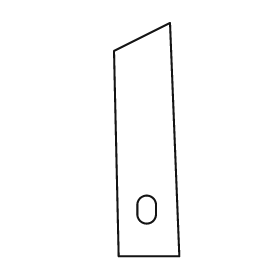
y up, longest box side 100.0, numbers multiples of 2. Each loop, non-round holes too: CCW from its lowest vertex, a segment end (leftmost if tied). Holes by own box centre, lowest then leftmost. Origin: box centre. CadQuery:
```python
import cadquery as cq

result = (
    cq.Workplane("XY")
    .moveTo(-12.0, -50.0)
    .lineTo(14.0, -50.0)
    .lineTo(10.0, 50.0)
    .lineTo(-14.0, 38.0)
    .close()
    .moveTo(-4.0, -32.0)
    .threePointArc((0.0, -36.0), (4.0, -32.0))
    .lineTo(4.0, -28.0)
    .threePointArc((0.0, -24.0), (-4.0, -28.0))
    .close()
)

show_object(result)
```